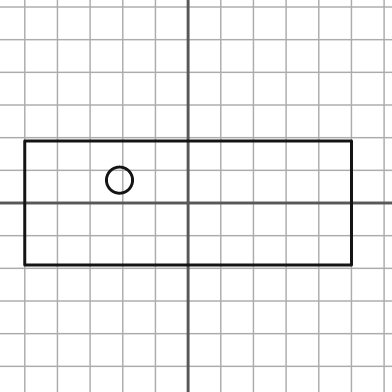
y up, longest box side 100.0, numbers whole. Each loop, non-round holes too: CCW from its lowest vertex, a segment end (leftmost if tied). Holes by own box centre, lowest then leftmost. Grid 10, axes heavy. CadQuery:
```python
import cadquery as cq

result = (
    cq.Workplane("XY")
    .moveTo(-50.0, -19.0)
    .lineTo(50.0, -19.0)
    .lineTo(50.0, 19.0)
    .lineTo(-50.0, 19.0)
    .close()
    .moveTo(-21.0, 7.0)
    .circle(4.0)
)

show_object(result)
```